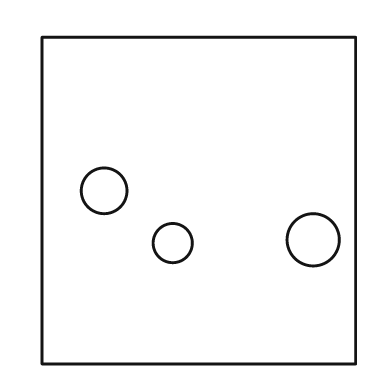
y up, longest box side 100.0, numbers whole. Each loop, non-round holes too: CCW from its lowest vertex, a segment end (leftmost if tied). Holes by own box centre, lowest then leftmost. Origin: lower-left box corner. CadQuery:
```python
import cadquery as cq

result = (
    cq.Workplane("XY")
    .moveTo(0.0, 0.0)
    .lineTo(96.0, 0.0)
    .lineTo(96.0, 100.0)
    .lineTo(0.0, 100.0)
    .close()
    .moveTo(40.0, 37.0)
    .circle(6.0)
    .moveTo(83.0, 38.0)
    .circle(8.0)
    .moveTo(19.0, 53.0)
    .circle(7.0)
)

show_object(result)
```